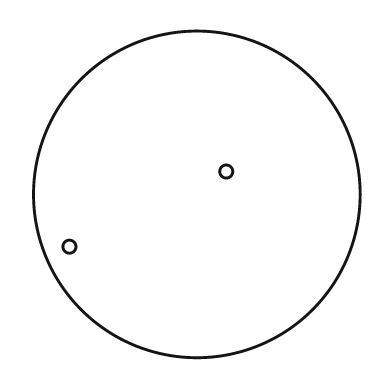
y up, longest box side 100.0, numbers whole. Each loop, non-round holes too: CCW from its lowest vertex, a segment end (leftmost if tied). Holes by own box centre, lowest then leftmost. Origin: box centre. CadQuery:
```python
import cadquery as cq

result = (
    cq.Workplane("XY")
    .moveTo(0.0, 0.0)
    .circle(50.0)
    .moveTo(-39.0, -16.0)
    .circle(2.0)
    .moveTo(9.0, 7.0)
    .circle(2.0)
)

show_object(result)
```